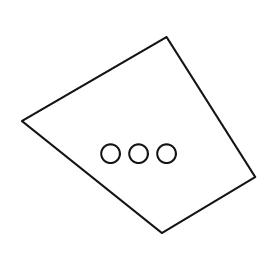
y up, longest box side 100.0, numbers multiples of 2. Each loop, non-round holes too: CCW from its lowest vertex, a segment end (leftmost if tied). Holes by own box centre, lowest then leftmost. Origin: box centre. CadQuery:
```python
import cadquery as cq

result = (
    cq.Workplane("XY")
    .moveTo(10.0, -42.0)
    .lineTo(50.0, -18.0)
    .lineTo(12.0, 42.0)
    .lineTo(-50.0, 6.0)
    .close()
    .moveTo(-12.0, -8.0)
    .circle(4.0)
    .moveTo(0.0, -8.0)
    .circle(4.0)
    .moveTo(12.0, -8.0)
    .circle(4.0)
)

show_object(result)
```